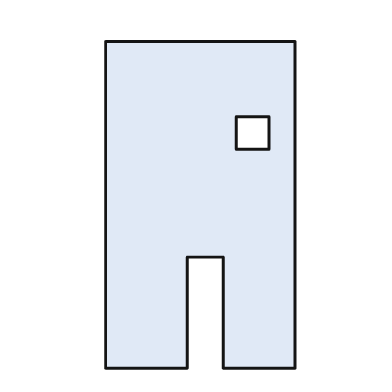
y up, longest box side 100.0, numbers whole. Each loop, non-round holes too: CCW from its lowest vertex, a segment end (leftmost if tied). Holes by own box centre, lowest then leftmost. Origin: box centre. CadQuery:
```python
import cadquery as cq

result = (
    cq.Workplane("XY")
    .moveTo(-29.0, -50.0)
    .lineTo(-4.0, -50.0)
    .lineTo(-4.0, -16.0)
    .lineTo(7.0, -16.0)
    .lineTo(7.0, -50.0)
    .lineTo(29.0, -50.0)
    .lineTo(29.0, 50.0)
    .lineTo(-29.0, 50.0)
    .close()
    .moveTo(11.0, 17.0)
    .lineTo(21.0, 17.0)
    .lineTo(21.0, 27.0)
    .lineTo(11.0, 27.0)
    .close()
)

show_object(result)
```